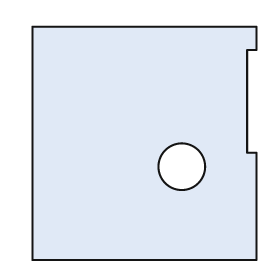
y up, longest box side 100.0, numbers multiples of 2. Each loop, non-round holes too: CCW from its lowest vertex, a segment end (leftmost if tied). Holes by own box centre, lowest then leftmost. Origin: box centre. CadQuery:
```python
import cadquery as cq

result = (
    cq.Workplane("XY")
    .moveTo(-48.0, -50.0)
    .lineTo(48.0, -50.0)
    .lineTo(48.0, -4.0)
    .lineTo(44.0, -4.0)
    .lineTo(44.0, 40.0)
    .lineTo(48.0, 40.0)
    .lineTo(48.0, 50.0)
    .lineTo(-48.0, 50.0)
    .close()
    .moveTo(16.0, -10.0)
    .circle(10.0)
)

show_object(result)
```